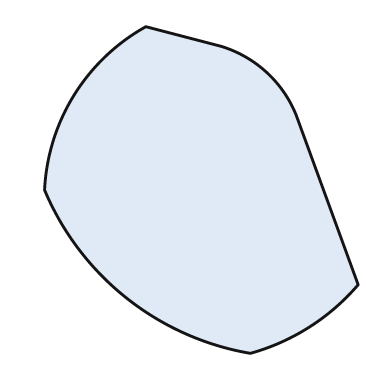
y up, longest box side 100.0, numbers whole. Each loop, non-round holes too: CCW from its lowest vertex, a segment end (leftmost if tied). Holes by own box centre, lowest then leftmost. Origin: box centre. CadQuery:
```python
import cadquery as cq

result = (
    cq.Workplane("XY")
    .moveTo(15.0, -50.0)
    .threePointArc((33.0, -42.0), (48.0, -29.0))
    .lineTo(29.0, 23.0)
    .threePointArc((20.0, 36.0), (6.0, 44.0))
    .lineTo(-17.0, 50.0)
    .threePointArc((-39.0, 29.0), (-48.0, 0.0))
    .threePointArc((-23.0, -33.0), (15.0, -50.0))
    .close()
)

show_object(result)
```